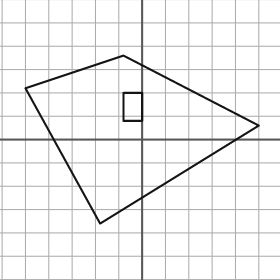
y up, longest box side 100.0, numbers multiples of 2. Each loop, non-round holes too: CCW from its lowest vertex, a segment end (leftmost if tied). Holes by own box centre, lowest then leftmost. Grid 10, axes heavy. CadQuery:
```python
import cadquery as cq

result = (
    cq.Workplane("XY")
    .moveTo(-18.0, -36.0)
    .lineTo(50.0, 6.0)
    .lineTo(-8.0, 36.0)
    .lineTo(-50.0, 22.0)
    .close()
    .moveTo(-8.0, 8.0)
    .lineTo(0.0, 8.0)
    .lineTo(0.0, 20.0)
    .lineTo(-8.0, 20.0)
    .close()
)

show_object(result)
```